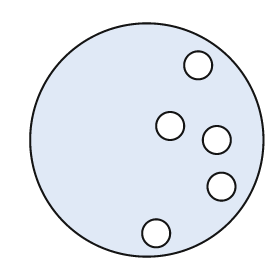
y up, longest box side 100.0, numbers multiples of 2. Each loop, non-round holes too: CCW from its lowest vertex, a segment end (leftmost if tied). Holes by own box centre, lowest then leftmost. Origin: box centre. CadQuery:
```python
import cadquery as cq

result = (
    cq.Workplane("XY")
    .moveTo(0.0, 0.0)
    .circle(50.0)
    .moveTo(4.0, -40.0)
    .circle(6.0)
    .moveTo(32.0, -20.0)
    .circle(6.0)
    .moveTo(30.0, 0.0)
    .circle(6.0)
    .moveTo(10.0, 6.0)
    .circle(6.0)
    .moveTo(22.0, 32.0)
    .circle(6.0)
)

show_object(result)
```